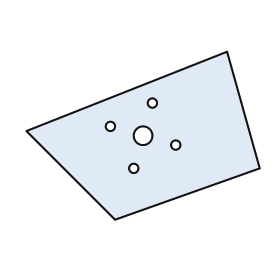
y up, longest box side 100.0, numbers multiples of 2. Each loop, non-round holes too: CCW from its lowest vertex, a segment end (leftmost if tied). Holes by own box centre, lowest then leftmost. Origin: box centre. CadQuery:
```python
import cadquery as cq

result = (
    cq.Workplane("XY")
    .moveTo(-12.0, -36.0)
    .lineTo(50.0, -14.0)
    .lineTo(36.0, 36.0)
    .lineTo(-50.0, 2.0)
    .close()
    .moveTo(-4.0, -14.0)
    .circle(2.0)
    .moveTo(14.0, -4.0)
    .circle(2.0)
    .moveTo(0.0, 0.0)
    .circle(4.0)
    .moveTo(-14.0, 4.0)
    .circle(2.0)
    .moveTo(4.0, 14.0)
    .circle(2.0)
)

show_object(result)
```